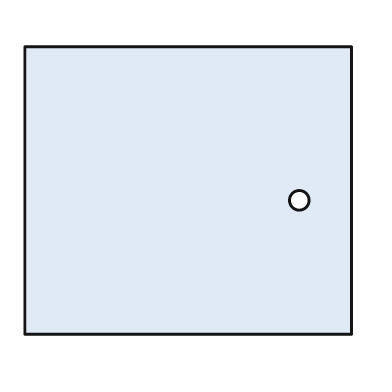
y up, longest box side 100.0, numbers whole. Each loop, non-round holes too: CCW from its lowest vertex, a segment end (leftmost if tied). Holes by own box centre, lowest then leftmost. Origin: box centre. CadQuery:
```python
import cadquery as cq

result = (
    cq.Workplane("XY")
    .moveTo(-50.0, -44.0)
    .lineTo(50.0, -44.0)
    .lineTo(50.0, 44.0)
    .lineTo(-50.0, 44.0)
    .close()
    .moveTo(34.0, -3.0)
    .circle(3.0)
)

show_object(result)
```